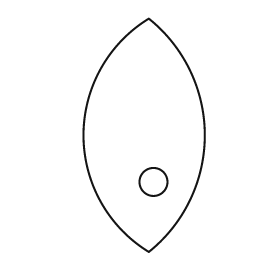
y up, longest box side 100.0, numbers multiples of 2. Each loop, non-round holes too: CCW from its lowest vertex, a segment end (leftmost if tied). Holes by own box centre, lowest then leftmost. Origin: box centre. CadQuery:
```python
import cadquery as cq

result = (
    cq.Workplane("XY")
    .moveTo(2.0, -50.0)
    .threePointArc((26.0, 0.0), (2.0, 50.0))
    .threePointArc((-26.0, 0.0), (2.0, -50.0))
    .close()
    .moveTo(4.0, -20.0)
    .circle(6.0)
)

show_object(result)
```